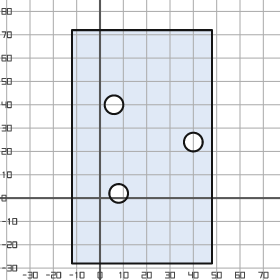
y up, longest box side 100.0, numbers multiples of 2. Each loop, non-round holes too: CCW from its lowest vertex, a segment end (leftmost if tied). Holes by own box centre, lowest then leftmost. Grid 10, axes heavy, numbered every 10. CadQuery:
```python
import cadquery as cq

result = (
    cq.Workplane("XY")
    .moveTo(-12.0, -28.0)
    .lineTo(48.0, -28.0)
    .lineTo(48.0, 72.0)
    .lineTo(-12.0, 72.0)
    .close()
    .moveTo(8.0, 2.0)
    .circle(4.0)
    .moveTo(40.0, 24.0)
    .circle(4.0)
    .moveTo(6.0, 40.0)
    .circle(4.0)
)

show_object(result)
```